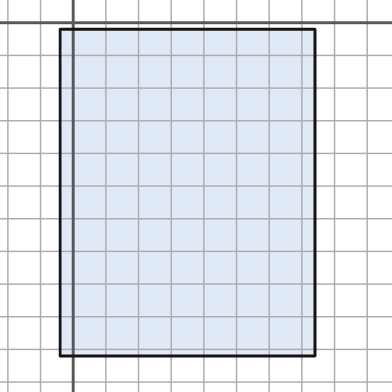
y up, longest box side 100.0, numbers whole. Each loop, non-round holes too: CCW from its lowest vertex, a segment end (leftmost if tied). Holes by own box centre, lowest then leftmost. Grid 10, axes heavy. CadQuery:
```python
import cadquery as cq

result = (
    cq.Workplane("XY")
    .moveTo(-4.0, -102.0)
    .lineTo(74.0, -102.0)
    .lineTo(74.0, -2.0)
    .lineTo(-4.0, -2.0)
    .close()
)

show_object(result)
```